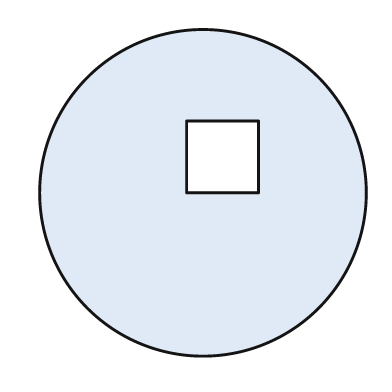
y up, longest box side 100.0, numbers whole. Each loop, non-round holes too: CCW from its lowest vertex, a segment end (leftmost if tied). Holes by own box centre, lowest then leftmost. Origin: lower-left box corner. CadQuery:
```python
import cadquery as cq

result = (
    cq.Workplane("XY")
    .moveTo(50.0, 50.0)
    .circle(50.0)
    .moveTo(45.0, 50.0)
    .lineTo(67.0, 50.0)
    .lineTo(67.0, 72.0)
    .lineTo(45.0, 72.0)
    .close()
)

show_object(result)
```